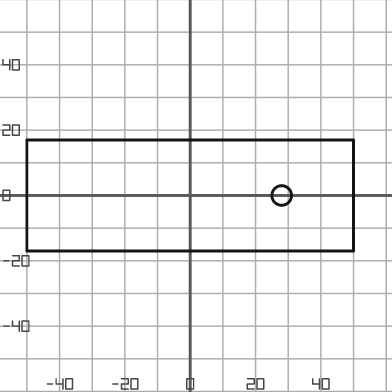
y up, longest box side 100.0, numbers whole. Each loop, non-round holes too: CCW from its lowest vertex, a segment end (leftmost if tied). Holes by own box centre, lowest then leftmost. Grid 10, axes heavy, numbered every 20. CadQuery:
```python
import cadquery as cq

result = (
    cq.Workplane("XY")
    .moveTo(-50.0, -17.0)
    .lineTo(50.0, -17.0)
    .lineTo(50.0, 17.0)
    .lineTo(-50.0, 17.0)
    .close()
    .moveTo(28.0, 0.0)
    .circle(3.0)
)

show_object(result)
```